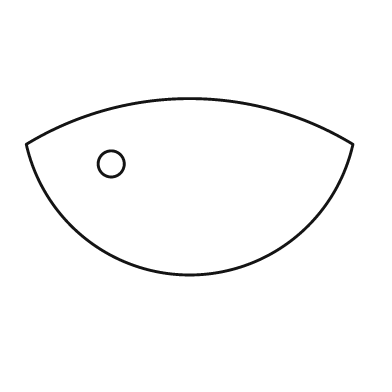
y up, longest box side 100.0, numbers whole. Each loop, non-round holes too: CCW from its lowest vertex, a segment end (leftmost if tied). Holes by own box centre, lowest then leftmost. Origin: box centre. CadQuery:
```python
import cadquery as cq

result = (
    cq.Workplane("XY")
    .moveTo(-50.0, 13.0)
    .threePointArc((0.0, -27.0), (50.0, 13.0))
    .threePointArc((0.0, 27.0), (-50.0, 13.0))
    .close()
    .moveTo(-24.0, 7.0)
    .circle(4.0)
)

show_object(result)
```